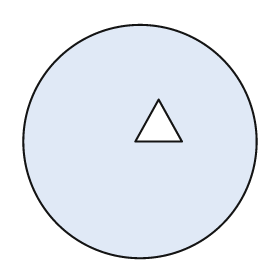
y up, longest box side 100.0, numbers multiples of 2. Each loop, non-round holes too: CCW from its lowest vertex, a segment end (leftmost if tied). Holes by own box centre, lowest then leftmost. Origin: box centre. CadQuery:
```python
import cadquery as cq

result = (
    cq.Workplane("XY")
    .moveTo(0.0, 0.0)
    .circle(50.0)
    .moveTo(-2.0, 0.0)
    .lineTo(18.0, 0.0)
    .lineTo(8.0, 18.0)
    .close()
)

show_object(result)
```